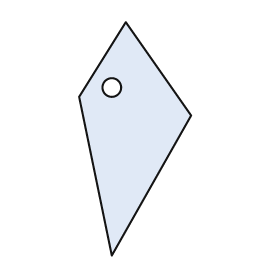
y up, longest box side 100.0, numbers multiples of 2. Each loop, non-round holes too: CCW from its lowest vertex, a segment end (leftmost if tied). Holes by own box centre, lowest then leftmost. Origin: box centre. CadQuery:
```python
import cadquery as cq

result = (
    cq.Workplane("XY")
    .moveTo(-10.0, -50.0)
    .lineTo(24.0, 10.0)
    .lineTo(-4.0, 50.0)
    .lineTo(-24.0, 18.0)
    .close()
    .moveTo(-10.0, 22.0)
    .circle(4.0)
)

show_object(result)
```